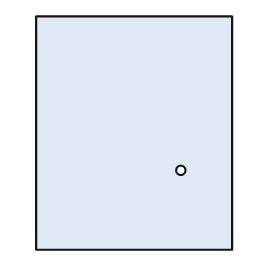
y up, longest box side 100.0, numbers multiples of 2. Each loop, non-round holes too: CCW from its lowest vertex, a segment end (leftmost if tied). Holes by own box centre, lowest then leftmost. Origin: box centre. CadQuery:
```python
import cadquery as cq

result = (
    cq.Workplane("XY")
    .moveTo(-42.0, -50.0)
    .lineTo(42.0, -50.0)
    .lineTo(42.0, 50.0)
    .lineTo(-42.0, 50.0)
    .close()
    .moveTo(20.0, -16.0)
    .circle(2.0)
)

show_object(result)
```